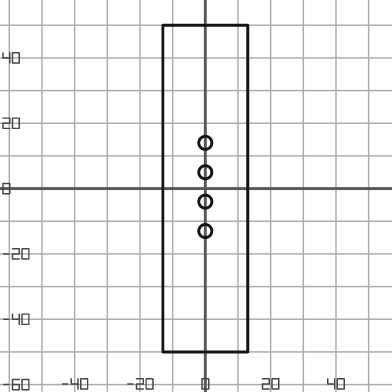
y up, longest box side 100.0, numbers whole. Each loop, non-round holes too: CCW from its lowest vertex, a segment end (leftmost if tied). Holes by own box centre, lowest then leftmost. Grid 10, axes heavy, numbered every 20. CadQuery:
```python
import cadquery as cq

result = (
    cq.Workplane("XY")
    .moveTo(-13.0, -50.0)
    .lineTo(13.0, -50.0)
    .lineTo(13.0, 50.0)
    .lineTo(-13.0, 50.0)
    .close()
    .moveTo(0.0, -13.0)
    .circle(2.0)
    .moveTo(0.0, -4.0)
    .circle(2.0)
    .moveTo(0.0, 5.0)
    .circle(2.0)
    .moveTo(0.0, 14.0)
    .circle(2.0)
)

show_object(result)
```